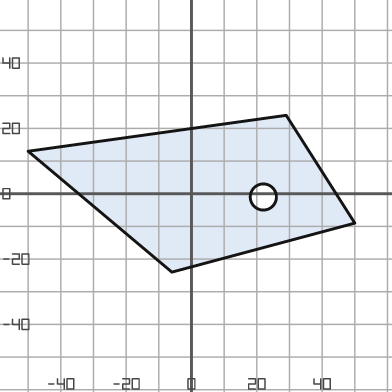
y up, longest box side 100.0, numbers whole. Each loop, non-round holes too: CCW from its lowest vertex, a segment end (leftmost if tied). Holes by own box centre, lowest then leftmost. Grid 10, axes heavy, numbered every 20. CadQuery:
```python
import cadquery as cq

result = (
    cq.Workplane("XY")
    .moveTo(-6.0, -24.0)
    .lineTo(50.0, -9.0)
    .lineTo(29.0, 24.0)
    .lineTo(-50.0, 13.0)
    .close()
    .moveTo(22.0, -1.0)
    .circle(4.0)
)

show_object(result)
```